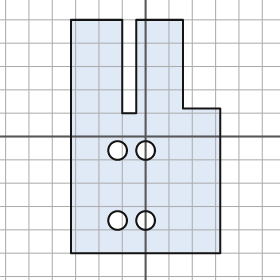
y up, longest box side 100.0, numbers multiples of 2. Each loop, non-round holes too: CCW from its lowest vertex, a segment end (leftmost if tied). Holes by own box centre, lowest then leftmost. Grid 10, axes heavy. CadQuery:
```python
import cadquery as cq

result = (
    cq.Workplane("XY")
    .moveTo(-32.0, -50.0)
    .lineTo(32.0, -50.0)
    .lineTo(32.0, 12.0)
    .lineTo(16.0, 12.0)
    .lineTo(16.0, 50.0)
    .lineTo(-4.0, 50.0)
    .lineTo(-4.0, 10.0)
    .lineTo(-10.0, 10.0)
    .lineTo(-10.0, 50.0)
    .lineTo(-32.0, 50.0)
    .close()
    .moveTo(-12.0, -36.0)
    .circle(4.0)
    .moveTo(0.0, -36.0)
    .circle(4.0)
    .moveTo(-12.0, -6.0)
    .circle(4.0)
    .moveTo(0.0, -6.0)
    .circle(4.0)
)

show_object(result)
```